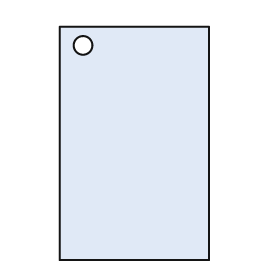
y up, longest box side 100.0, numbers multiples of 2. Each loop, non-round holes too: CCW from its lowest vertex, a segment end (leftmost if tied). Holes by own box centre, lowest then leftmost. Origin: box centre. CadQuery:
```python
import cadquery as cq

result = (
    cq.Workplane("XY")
    .moveTo(-32.0, -50.0)
    .lineTo(32.0, -50.0)
    .lineTo(32.0, 50.0)
    .lineTo(-32.0, 50.0)
    .close()
    .moveTo(-22.0, 42.0)
    .circle(4.0)
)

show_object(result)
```